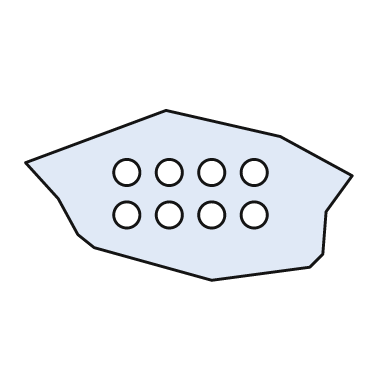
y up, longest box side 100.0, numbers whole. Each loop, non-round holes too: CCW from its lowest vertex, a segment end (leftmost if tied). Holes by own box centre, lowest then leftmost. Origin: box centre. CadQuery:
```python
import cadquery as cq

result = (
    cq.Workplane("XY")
    .moveTo(7.0, -26.0)
    .lineTo(37.0, -22.0)
    .lineTo(41.0, -18.0)
    .lineTo(42.0, -5.0)
    .lineTo(50.0, 6.0)
    .lineTo(28.0, 18.0)
    .lineTo(-7.0, 26.0)
    .lineTo(-50.0, 10.0)
    .lineTo(-40.0, -1.0)
    .lineTo(-34.0, -12.0)
    .lineTo(-29.0, -16.0)
    .close()
    .moveTo(-19.0, -6.0)
    .circle(4.0)
    .moveTo(-6.0, -6.0)
    .circle(4.0)
    .moveTo(7.0, -6.0)
    .circle(4.0)
    .moveTo(20.0, -6.0)
    .circle(4.0)
    .moveTo(-19.0, 7.0)
    .circle(4.0)
    .moveTo(-6.0, 7.0)
    .circle(4.0)
    .moveTo(7.0, 7.0)
    .circle(4.0)
    .moveTo(20.0, 7.0)
    .circle(4.0)
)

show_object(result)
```